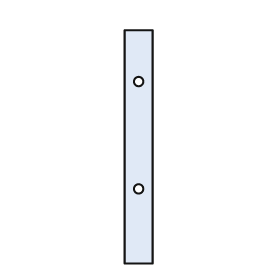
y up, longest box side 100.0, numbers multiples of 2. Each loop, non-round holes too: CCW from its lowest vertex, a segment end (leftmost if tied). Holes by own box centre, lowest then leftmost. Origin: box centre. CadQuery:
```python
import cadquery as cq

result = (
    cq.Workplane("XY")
    .moveTo(-6.0, -50.0)
    .lineTo(6.0, -50.0)
    .lineTo(6.0, 50.0)
    .lineTo(-6.0, 50.0)
    .close()
    .moveTo(0.0, -18.0)
    .circle(2.0)
    .moveTo(0.0, 28.0)
    .circle(2.0)
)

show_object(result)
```